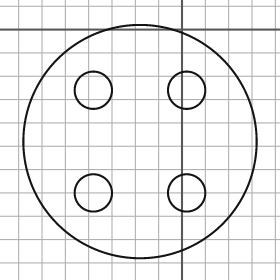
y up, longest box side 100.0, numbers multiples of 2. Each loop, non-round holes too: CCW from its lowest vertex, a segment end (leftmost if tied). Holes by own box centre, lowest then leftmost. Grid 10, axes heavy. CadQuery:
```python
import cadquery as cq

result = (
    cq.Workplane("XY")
    .moveTo(-18.0, -48.0)
    .circle(50.0)
    .moveTo(-38.0, -70.0)
    .circle(8.0)
    .moveTo(2.0, -70.0)
    .circle(8.0)
    .moveTo(-38.0, -26.0)
    .circle(8.0)
    .moveTo(2.0, -26.0)
    .circle(8.0)
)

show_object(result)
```